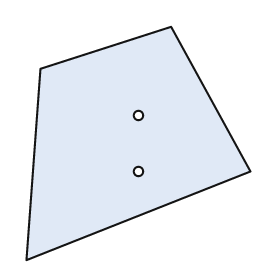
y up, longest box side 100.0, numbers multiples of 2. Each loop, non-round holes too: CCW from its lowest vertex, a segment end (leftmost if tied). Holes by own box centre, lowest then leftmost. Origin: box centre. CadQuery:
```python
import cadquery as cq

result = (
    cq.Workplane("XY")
    .moveTo(-48.0, -50.0)
    .lineTo(48.0, -12.0)
    .lineTo(14.0, 50.0)
    .lineTo(-42.0, 32.0)
    .close()
    .moveTo(0.0, -12.0)
    .circle(2.0)
    .moveTo(0.0, 12.0)
    .circle(2.0)
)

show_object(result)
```